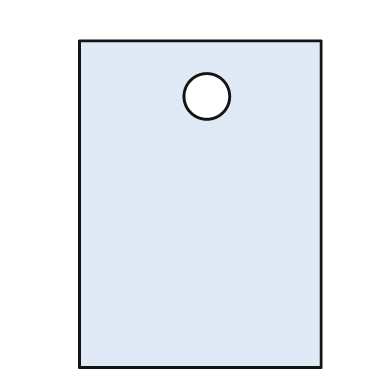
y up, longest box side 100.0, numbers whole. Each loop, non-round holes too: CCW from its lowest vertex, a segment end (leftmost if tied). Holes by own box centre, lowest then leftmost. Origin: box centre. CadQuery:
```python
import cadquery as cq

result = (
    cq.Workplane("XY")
    .moveTo(-37.0, -50.0)
    .lineTo(37.0, -50.0)
    .lineTo(37.0, 50.0)
    .lineTo(-37.0, 50.0)
    .close()
    .moveTo(2.0, 33.0)
    .circle(7.0)
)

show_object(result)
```